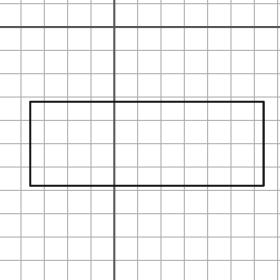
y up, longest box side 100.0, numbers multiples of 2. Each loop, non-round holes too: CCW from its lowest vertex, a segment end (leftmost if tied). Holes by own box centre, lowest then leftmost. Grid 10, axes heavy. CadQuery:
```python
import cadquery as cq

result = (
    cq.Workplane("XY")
    .moveTo(-36.0, -68.0)
    .lineTo(64.0, -68.0)
    .lineTo(64.0, -32.0)
    .lineTo(-36.0, -32.0)
    .close()
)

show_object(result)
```